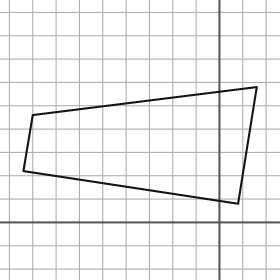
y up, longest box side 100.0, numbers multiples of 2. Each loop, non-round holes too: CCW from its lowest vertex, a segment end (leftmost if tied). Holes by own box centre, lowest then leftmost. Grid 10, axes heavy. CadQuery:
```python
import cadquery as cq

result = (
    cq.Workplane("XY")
    .moveTo(8.0, 8.0)
    .lineTo(16.0, 58.0)
    .lineTo(-80.0, 46.0)
    .lineTo(-84.0, 22.0)
    .close()
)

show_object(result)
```